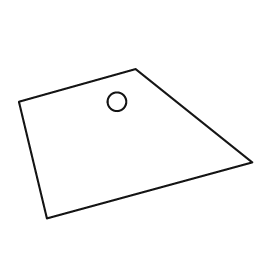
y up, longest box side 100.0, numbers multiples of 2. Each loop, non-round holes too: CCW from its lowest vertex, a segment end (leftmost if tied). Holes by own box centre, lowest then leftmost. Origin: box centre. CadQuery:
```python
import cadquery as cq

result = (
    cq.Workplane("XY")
    .moveTo(-38.0, -32.0)
    .lineTo(50.0, -8.0)
    .lineTo(0.0, 32.0)
    .lineTo(-50.0, 18.0)
    .close()
    .moveTo(-8.0, 18.0)
    .circle(4.0)
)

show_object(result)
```